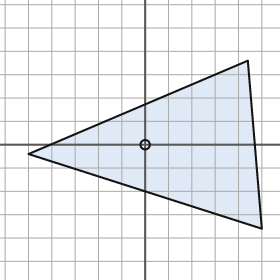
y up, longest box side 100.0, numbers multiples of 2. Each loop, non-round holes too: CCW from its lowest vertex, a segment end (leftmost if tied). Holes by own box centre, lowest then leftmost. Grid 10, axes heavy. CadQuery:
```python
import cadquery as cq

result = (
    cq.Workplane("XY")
    .moveTo(50.0, -36.0)
    .lineTo(44.0, 36.0)
    .lineTo(-50.0, -4.0)
    .close()
    .moveTo(0.0, 0.0)
    .circle(2.0)
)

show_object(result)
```